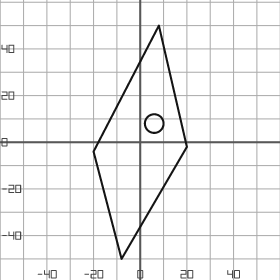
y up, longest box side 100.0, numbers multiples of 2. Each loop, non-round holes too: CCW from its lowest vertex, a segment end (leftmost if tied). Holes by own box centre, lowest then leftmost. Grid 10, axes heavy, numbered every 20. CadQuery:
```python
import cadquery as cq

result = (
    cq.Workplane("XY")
    .moveTo(-8.0, -50.0)
    .lineTo(20.0, -2.0)
    .lineTo(8.0, 50.0)
    .lineTo(-20.0, -4.0)
    .close()
    .moveTo(6.0, 8.0)
    .circle(4.0)
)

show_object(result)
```